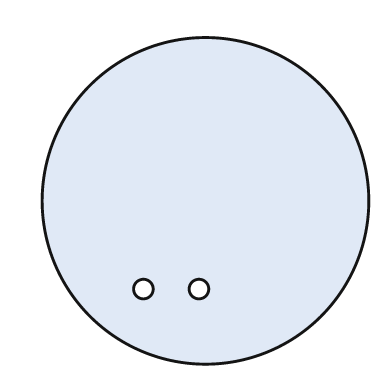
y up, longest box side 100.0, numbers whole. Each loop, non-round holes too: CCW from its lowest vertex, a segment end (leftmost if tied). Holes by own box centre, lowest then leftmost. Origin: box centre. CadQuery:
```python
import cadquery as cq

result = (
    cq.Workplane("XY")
    .moveTo(0.0, 0.0)
    .circle(50.0)
    .moveTo(-19.0, -27.0)
    .circle(3.0)
    .moveTo(-2.0, -27.0)
    .circle(3.0)
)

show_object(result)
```